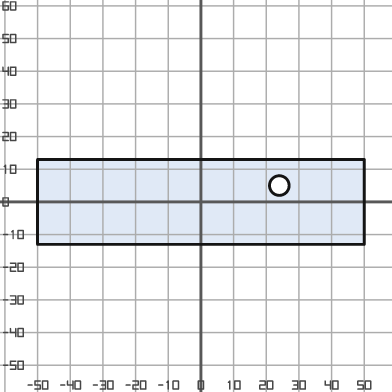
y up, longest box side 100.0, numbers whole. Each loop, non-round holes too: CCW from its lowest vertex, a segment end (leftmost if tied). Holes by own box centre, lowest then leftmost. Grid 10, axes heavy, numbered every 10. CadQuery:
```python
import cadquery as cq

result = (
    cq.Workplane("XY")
    .moveTo(-50.0, -13.0)
    .lineTo(50.0, -13.0)
    .lineTo(50.0, 13.0)
    .lineTo(-50.0, 13.0)
    .close()
    .moveTo(24.0, 5.0)
    .circle(3.0)
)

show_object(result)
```